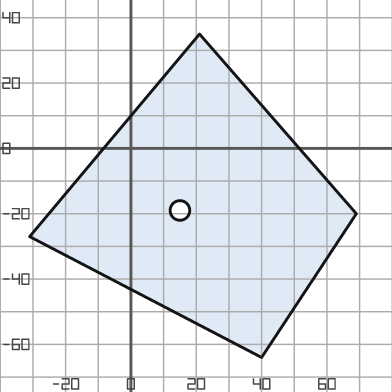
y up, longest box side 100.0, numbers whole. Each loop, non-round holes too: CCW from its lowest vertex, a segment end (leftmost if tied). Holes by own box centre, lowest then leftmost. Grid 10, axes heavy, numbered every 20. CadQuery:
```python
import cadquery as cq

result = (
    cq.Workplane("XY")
    .moveTo(40.0, -64.0)
    .lineTo(69.0, -20.0)
    .lineTo(21.0, 35.0)
    .lineTo(-31.0, -27.0)
    .close()
    .moveTo(15.0, -19.0)
    .circle(3.0)
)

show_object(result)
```